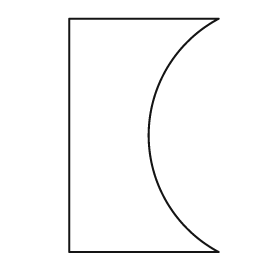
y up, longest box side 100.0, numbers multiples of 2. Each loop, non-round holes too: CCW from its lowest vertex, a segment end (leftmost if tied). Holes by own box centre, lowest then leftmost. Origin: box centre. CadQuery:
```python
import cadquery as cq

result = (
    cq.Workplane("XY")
    .moveTo(-32.0, -50.0)
    .lineTo(32.0, -50.0)
    .threePointArc((2.0, 0.0), (32.0, 50.0))
    .lineTo(-32.0, 50.0)
    .close()
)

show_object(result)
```